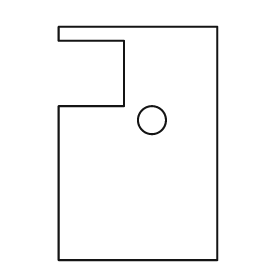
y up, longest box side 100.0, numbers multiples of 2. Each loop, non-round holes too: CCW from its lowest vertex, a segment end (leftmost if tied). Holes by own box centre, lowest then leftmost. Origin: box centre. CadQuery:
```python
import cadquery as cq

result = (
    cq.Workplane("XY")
    .moveTo(-34.0, -50.0)
    .lineTo(34.0, -50.0)
    .lineTo(34.0, 50.0)
    .lineTo(-34.0, 50.0)
    .lineTo(-34.0, 44.0)
    .lineTo(-6.0, 44.0)
    .lineTo(-6.0, 16.0)
    .lineTo(-34.0, 16.0)
    .close()
    .moveTo(6.0, 10.0)
    .circle(6.0)
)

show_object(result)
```